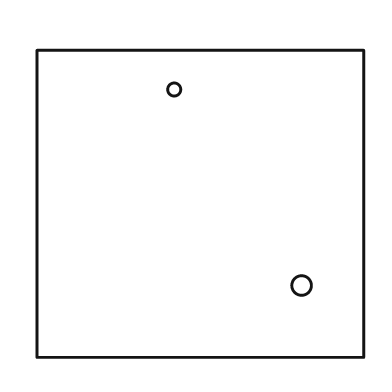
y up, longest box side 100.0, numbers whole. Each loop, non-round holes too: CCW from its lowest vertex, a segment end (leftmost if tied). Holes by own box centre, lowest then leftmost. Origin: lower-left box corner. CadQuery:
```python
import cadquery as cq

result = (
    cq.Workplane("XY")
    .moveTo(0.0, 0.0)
    .lineTo(100.0, 0.0)
    .lineTo(100.0, 94.0)
    .lineTo(0.0, 94.0)
    .close()
    .moveTo(81.0, 22.0)
    .circle(3.0)
    .moveTo(42.0, 82.0)
    .circle(2.0)
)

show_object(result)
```